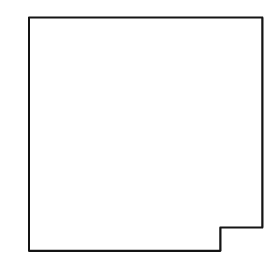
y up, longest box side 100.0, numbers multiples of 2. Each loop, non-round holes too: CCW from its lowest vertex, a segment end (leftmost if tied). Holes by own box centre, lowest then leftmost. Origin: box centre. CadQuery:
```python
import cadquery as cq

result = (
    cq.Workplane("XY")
    .moveTo(-50.0, -50.0)
    .lineTo(32.0, -50.0)
    .lineTo(32.0, -40.0)
    .lineTo(50.0, -40.0)
    .lineTo(50.0, 50.0)
    .lineTo(-50.0, 50.0)
    .close()
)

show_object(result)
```